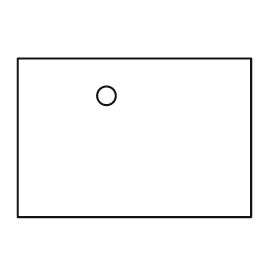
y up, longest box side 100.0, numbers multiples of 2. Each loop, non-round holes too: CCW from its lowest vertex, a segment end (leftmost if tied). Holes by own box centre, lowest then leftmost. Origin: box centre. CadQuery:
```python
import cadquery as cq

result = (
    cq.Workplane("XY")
    .moveTo(-50.0, -34.0)
    .lineTo(50.0, -34.0)
    .lineTo(50.0, 34.0)
    .lineTo(-50.0, 34.0)
    .close()
    .moveTo(-12.0, 18.0)
    .circle(4.0)
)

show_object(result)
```